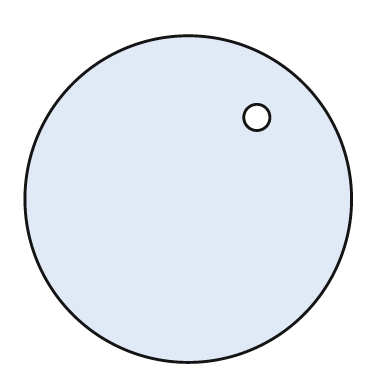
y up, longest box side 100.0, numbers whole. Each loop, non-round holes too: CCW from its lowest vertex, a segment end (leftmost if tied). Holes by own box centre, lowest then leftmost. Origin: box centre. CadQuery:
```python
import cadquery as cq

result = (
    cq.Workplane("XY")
    .moveTo(0.0, 0.0)
    .circle(50.0)
    .moveTo(21.0, 25.0)
    .circle(4.0)
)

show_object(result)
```